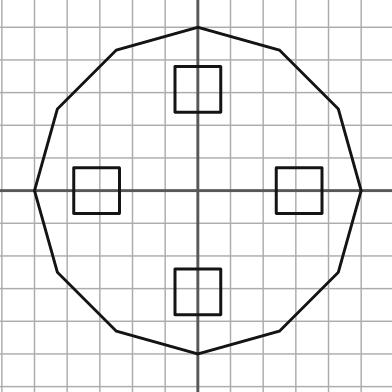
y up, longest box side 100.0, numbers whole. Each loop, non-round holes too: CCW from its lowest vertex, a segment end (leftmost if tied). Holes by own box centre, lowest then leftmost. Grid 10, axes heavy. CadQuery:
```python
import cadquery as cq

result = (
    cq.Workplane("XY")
    .moveTo(0.0, -50.0)
    .lineTo(25.0, -43.0)
    .lineTo(43.0, -25.0)
    .lineTo(50.0, 0.0)
    .lineTo(43.0, 25.0)
    .lineTo(25.0, 43.0)
    .lineTo(0.0, 50.0)
    .lineTo(-25.0, 43.0)
    .lineTo(-43.0, 25.0)
    .lineTo(-50.0, 0.0)
    .lineTo(-43.0, -25.0)
    .lineTo(-25.0, -43.0)
    .close()
    .moveTo(-7.0, -38.0)
    .lineTo(7.0, -38.0)
    .lineTo(7.0, -24.0)
    .lineTo(-7.0, -24.0)
    .close()
    .moveTo(-38.0, -7.0)
    .lineTo(-24.0, -7.0)
    .lineTo(-24.0, 7.0)
    .lineTo(-38.0, 7.0)
    .close()
    .moveTo(24.0, -7.0)
    .lineTo(38.0, -7.0)
    .lineTo(38.0, 7.0)
    .lineTo(24.0, 7.0)
    .close()
    .moveTo(-7.0, 24.0)
    .lineTo(7.0, 24.0)
    .lineTo(7.0, 38.0)
    .lineTo(-7.0, 38.0)
    .close()
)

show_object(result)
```